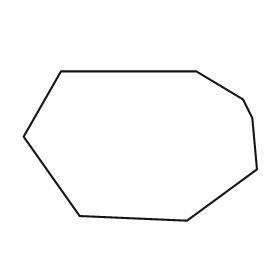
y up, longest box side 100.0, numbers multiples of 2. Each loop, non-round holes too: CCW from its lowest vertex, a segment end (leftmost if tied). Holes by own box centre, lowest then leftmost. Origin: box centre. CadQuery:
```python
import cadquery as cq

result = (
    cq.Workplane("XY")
    .moveTo(20.0, -32.0)
    .lineTo(50.0, -10.0)
    .lineTo(48.0, 12.0)
    .lineTo(44.0, 20.0)
    .lineTo(24.0, 32.0)
    .lineTo(-34.0, 32.0)
    .lineTo(-50.0, 4.0)
    .lineTo(-26.0, -30.0)
    .close()
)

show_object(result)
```